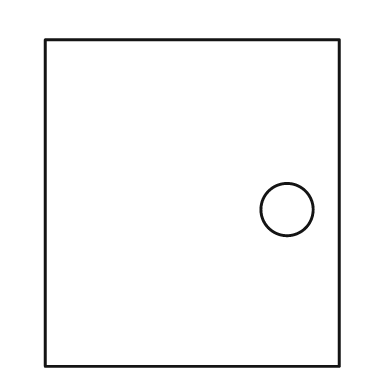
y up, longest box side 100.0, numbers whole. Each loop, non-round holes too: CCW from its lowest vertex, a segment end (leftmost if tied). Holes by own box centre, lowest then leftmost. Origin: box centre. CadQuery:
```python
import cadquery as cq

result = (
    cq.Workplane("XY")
    .moveTo(-45.0, -50.0)
    .lineTo(45.0, -50.0)
    .lineTo(45.0, 50.0)
    .lineTo(-45.0, 50.0)
    .close()
    .moveTo(29.0, -2.0)
    .circle(8.0)
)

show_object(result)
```